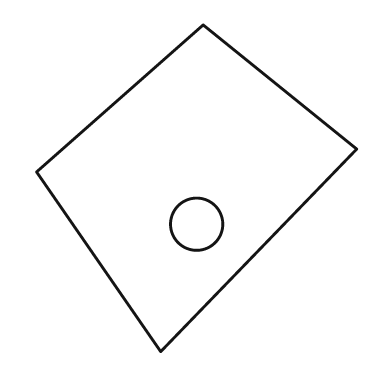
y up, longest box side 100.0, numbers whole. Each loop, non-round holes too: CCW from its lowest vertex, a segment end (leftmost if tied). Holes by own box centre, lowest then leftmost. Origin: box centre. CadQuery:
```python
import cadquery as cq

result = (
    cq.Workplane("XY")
    .moveTo(-11.0, -50.0)
    .lineTo(49.0, 12.0)
    .lineTo(2.0, 50.0)
    .lineTo(-49.0, 5.0)
    .close()
    .moveTo(0.0, -11.0)
    .circle(8.0)
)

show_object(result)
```